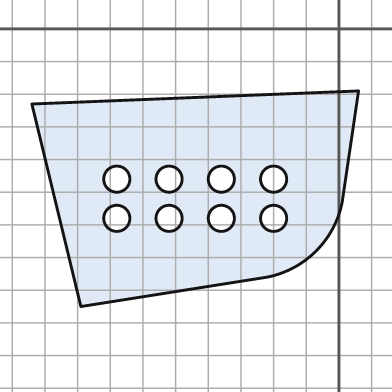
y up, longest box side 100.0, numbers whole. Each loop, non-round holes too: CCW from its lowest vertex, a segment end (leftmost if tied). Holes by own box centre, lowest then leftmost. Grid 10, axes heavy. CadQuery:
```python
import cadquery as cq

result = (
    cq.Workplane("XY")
    .moveTo(-79.0, -85.0)
    .lineTo(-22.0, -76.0)
    .threePointArc((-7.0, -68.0), (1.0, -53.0))
    .lineTo(6.0, -19.0)
    .lineTo(-94.0, -23.0)
    .close()
    .moveTo(-68.0, -58.0)
    .circle(4.0)
    .moveTo(-52.0, -58.0)
    .circle(4.0)
    .moveTo(-36.0, -58.0)
    .circle(4.0)
    .moveTo(-20.0, -58.0)
    .circle(4.0)
    .moveTo(-68.0, -46.0)
    .circle(4.0)
    .moveTo(-52.0, -46.0)
    .circle(4.0)
    .moveTo(-36.0, -46.0)
    .circle(4.0)
    .moveTo(-20.0, -46.0)
    .circle(4.0)
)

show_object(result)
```